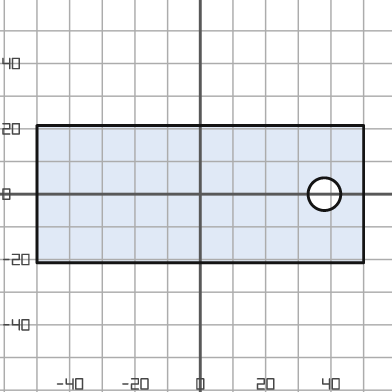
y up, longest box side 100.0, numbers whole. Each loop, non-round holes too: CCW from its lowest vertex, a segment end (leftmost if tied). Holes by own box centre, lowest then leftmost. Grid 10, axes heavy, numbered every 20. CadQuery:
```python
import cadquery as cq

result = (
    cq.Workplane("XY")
    .moveTo(-50.0, -21.0)
    .lineTo(50.0, -21.0)
    .lineTo(50.0, 21.0)
    .lineTo(-50.0, 21.0)
    .close()
    .moveTo(38.0, 0.0)
    .circle(5.0)
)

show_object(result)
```